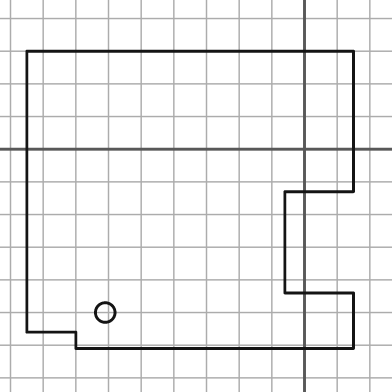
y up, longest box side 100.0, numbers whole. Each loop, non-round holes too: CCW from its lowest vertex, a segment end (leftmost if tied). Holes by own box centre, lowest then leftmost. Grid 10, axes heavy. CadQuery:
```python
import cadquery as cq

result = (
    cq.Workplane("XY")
    .moveTo(-70.0, -61.0)
    .lineTo(15.0, -61.0)
    .lineTo(15.0, -44.0)
    .lineTo(-6.0, -44.0)
    .lineTo(-6.0, -13.0)
    .lineTo(15.0, -13.0)
    .lineTo(15.0, 30.0)
    .lineTo(-85.0, 30.0)
    .lineTo(-85.0, -56.0)
    .lineTo(-70.0, -56.0)
    .close()
    .moveTo(-61.0, -50.0)
    .circle(3.0)
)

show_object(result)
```